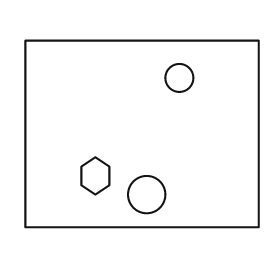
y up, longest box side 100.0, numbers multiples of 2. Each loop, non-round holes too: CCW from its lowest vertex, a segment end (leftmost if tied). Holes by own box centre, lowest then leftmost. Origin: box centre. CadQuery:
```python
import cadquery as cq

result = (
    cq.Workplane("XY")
    .moveTo(-50.0, -40.0)
    .lineTo(50.0, -40.0)
    .lineTo(50.0, 40.0)
    .lineTo(-50.0, 40.0)
    .close()
    .moveTo(2.0, -26.0)
    .circle(8.0)
    .moveTo(-20.0, -26.0)
    .lineTo(-14.0, -22.0)
    .lineTo(-14.0, -14.0)
    .lineTo(-20.0, -10.0)
    .lineTo(-26.0, -14.0)
    .lineTo(-26.0, -22.0)
    .close()
    .moveTo(16.0, 24.0)
    .circle(6.0)
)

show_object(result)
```